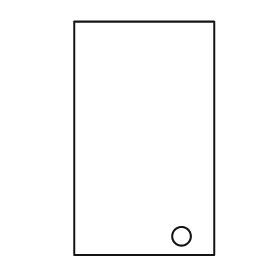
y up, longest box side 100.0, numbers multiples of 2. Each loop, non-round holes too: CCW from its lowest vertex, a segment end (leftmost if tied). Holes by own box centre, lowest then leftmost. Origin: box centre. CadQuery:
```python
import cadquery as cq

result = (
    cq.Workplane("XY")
    .moveTo(-30.0, -50.0)
    .lineTo(30.0, -50.0)
    .lineTo(30.0, 50.0)
    .lineTo(-30.0, 50.0)
    .close()
    .moveTo(16.0, -42.0)
    .circle(4.0)
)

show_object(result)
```